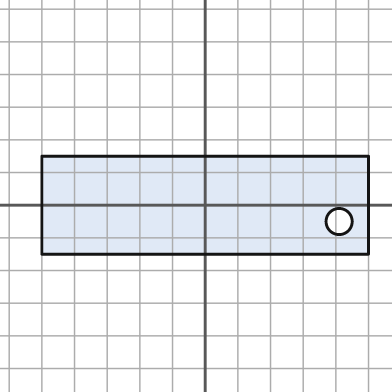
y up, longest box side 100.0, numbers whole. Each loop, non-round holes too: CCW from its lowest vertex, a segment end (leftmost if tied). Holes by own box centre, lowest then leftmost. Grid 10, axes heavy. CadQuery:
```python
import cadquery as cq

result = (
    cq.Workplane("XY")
    .moveTo(-50.0, -15.0)
    .lineTo(50.0, -15.0)
    .lineTo(50.0, 15.0)
    .lineTo(-50.0, 15.0)
    .close()
    .moveTo(41.0, -5.0)
    .circle(4.0)
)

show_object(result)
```